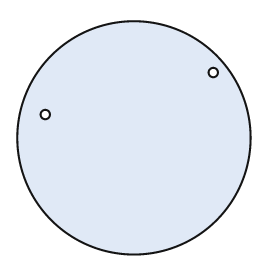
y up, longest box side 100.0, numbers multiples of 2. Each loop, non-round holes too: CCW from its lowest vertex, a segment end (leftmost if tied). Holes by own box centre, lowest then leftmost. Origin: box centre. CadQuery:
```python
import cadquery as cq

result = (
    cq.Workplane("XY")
    .moveTo(0.0, 0.0)
    .circle(50.0)
    .moveTo(-38.0, 10.0)
    .circle(2.0)
    .moveTo(34.0, 28.0)
    .circle(2.0)
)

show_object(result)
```